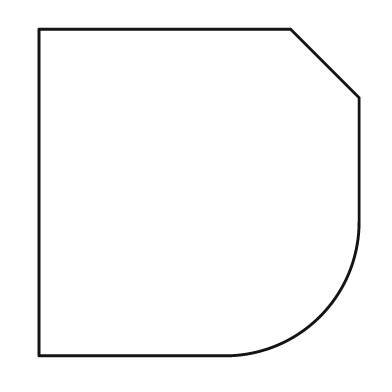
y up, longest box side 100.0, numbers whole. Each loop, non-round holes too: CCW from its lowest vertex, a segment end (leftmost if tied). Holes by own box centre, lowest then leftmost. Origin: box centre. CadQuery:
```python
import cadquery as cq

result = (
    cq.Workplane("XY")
    .moveTo(-49.0, -50.0)
    .lineTo(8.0, -50.0)
    .threePointArc((37.0, -38.0), (49.0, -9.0))
    .lineTo(49.0, 29.0)
    .lineTo(28.0, 50.0)
    .lineTo(-49.0, 50.0)
    .close()
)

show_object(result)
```